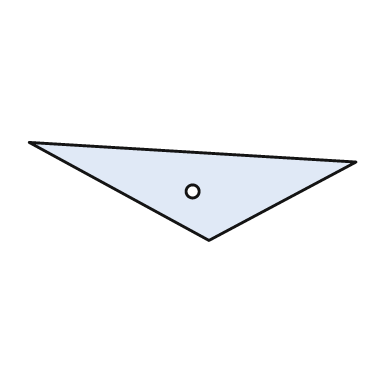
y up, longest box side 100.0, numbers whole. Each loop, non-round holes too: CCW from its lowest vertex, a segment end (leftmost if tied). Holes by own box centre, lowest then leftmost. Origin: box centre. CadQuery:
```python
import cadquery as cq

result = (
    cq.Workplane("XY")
    .moveTo(5.0, -15.0)
    .lineTo(50.0, 9.0)
    .lineTo(-50.0, 15.0)
    .close()
    .moveTo(0.0, 0.0)
    .circle(2.0)
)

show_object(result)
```